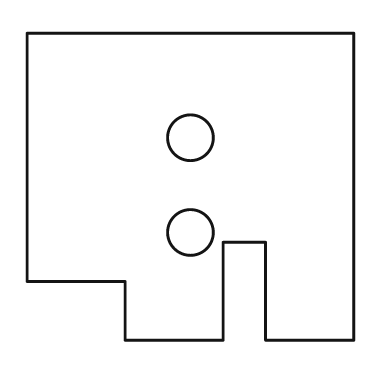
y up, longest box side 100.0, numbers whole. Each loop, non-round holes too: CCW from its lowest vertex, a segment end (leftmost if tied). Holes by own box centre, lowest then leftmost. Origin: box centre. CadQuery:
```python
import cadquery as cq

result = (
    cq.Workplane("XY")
    .moveTo(-20.0, -47.0)
    .lineTo(10.0, -47.0)
    .lineTo(10.0, -17.0)
    .lineTo(23.0, -17.0)
    .lineTo(23.0, -47.0)
    .lineTo(50.0, -47.0)
    .lineTo(50.0, 47.0)
    .lineTo(-50.0, 47.0)
    .lineTo(-50.0, -29.0)
    .lineTo(-20.0, -29.0)
    .close()
    .moveTo(0.0, -14.0)
    .circle(7.0)
    .moveTo(0.0, 15.0)
    .circle(7.0)
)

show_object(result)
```